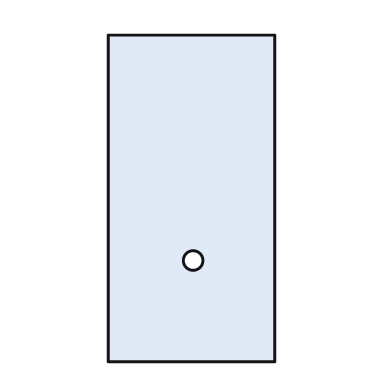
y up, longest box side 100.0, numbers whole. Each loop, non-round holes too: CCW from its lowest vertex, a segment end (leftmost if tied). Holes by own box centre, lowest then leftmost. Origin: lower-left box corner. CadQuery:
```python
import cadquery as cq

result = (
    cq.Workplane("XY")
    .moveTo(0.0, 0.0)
    .lineTo(51.0, 0.0)
    .lineTo(51.0, 100.0)
    .lineTo(0.0, 100.0)
    .close()
    .moveTo(26.0, 31.0)
    .circle(3.0)
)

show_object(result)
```